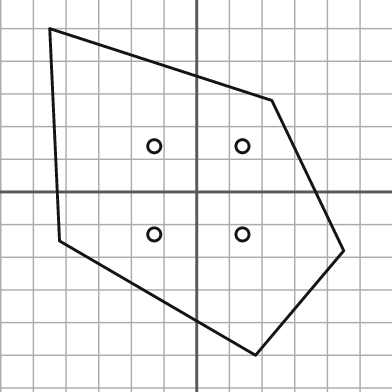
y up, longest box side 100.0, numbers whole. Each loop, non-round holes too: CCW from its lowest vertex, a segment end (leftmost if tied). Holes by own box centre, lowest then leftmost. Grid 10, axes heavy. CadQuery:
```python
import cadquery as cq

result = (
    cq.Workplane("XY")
    .moveTo(18.0, -50.0)
    .lineTo(45.0, -18.0)
    .lineTo(23.0, 28.0)
    .lineTo(-45.0, 50.0)
    .lineTo(-42.0, -15.0)
    .close()
    .moveTo(-13.0, -13.0)
    .circle(2.0)
    .moveTo(14.0, -13.0)
    .circle(2.0)
    .moveTo(-13.0, 14.0)
    .circle(2.0)
    .moveTo(14.0, 14.0)
    .circle(2.0)
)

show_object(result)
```